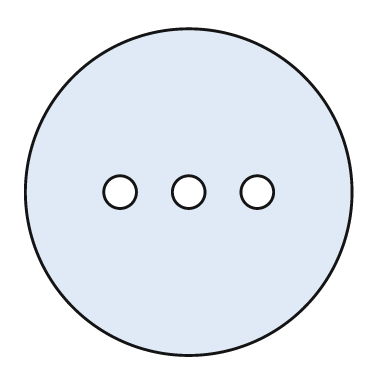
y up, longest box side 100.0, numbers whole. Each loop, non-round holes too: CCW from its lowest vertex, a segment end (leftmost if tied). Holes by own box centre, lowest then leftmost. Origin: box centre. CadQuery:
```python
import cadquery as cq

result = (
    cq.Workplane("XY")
    .moveTo(0.0, 0.0)
    .circle(50.0)
    .moveTo(-21.0, 0.0)
    .circle(5.0)
    .moveTo(0.0, 0.0)
    .circle(5.0)
    .moveTo(21.0, 0.0)
    .circle(5.0)
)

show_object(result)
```